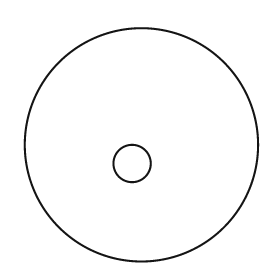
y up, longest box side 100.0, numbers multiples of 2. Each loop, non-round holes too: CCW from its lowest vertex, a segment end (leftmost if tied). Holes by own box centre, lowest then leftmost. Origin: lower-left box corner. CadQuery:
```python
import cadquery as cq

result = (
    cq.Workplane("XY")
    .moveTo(50.0, 50.0)
    .circle(50.0)
    .moveTo(46.0, 42.0)
    .circle(8.0)
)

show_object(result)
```